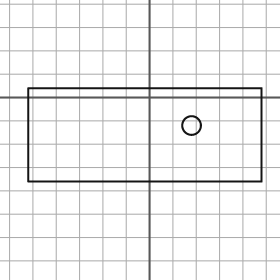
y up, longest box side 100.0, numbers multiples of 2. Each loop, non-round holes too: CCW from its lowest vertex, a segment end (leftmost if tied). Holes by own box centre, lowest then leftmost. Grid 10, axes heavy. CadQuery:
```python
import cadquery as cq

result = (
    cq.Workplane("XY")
    .moveTo(-52.0, -36.0)
    .lineTo(48.0, -36.0)
    .lineTo(48.0, 4.0)
    .lineTo(-52.0, 4.0)
    .close()
    .moveTo(18.0, -12.0)
    .circle(4.0)
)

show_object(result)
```